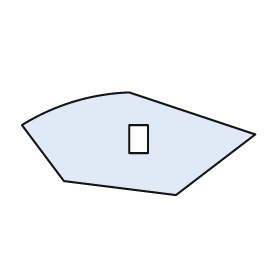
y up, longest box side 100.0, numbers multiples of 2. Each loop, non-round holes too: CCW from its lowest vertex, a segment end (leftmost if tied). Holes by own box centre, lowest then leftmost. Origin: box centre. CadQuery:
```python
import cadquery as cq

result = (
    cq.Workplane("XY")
    .moveTo(16.0, -22.0)
    .lineTo(50.0, 4.0)
    .lineTo(-4.0, 22.0)
    .threePointArc((-28.0, 18.0), (-50.0, 8.0))
    .lineTo(-32.0, -16.0)
    .close()
    .moveTo(-4.0, -4.0)
    .lineTo(4.0, -4.0)
    .lineTo(4.0, 8.0)
    .lineTo(-4.0, 8.0)
    .close()
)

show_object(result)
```